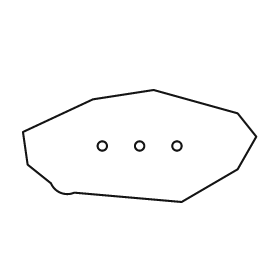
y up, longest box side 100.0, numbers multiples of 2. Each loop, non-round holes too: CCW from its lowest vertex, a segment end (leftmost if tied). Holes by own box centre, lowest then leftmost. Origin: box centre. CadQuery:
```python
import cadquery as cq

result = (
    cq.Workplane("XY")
    .moveTo(18.0, -24.0)
    .lineTo(42.0, -10.0)
    .lineTo(50.0, 4.0)
    .lineTo(42.0, 14.0)
    .lineTo(6.0, 24.0)
    .lineTo(-20.0, 20.0)
    .lineTo(-50.0, 6.0)
    .lineTo(-48.0, -8.0)
    .lineTo(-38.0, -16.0)
    .threePointArc((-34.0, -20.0), (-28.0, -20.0))
    .close()
    .moveTo(-16.0, 0.0)
    .circle(2.0)
    .moveTo(0.0, 0.0)
    .circle(2.0)
    .moveTo(16.0, 0.0)
    .circle(2.0)
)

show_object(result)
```